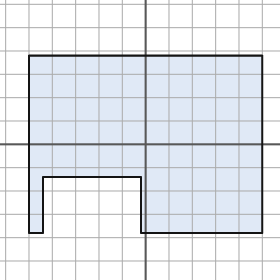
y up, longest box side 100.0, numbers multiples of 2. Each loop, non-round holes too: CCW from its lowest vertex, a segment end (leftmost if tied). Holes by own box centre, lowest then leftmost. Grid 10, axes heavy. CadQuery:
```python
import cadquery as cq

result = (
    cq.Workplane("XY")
    .moveTo(-50.0, -38.0)
    .lineTo(-44.0, -38.0)
    .lineTo(-44.0, -14.0)
    .lineTo(-2.0, -14.0)
    .lineTo(-2.0, -38.0)
    .lineTo(50.0, -38.0)
    .lineTo(50.0, 38.0)
    .lineTo(-50.0, 38.0)
    .close()
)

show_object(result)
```